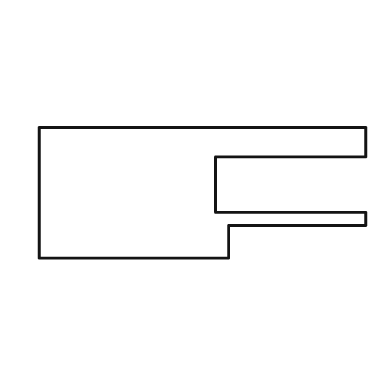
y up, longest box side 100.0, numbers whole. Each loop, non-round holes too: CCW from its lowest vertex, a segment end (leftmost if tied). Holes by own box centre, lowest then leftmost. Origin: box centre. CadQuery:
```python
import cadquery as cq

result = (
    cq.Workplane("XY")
    .moveTo(-50.0, -20.0)
    .lineTo(8.0, -20.0)
    .lineTo(8.0, -10.0)
    .lineTo(50.0, -10.0)
    .lineTo(50.0, -6.0)
    .lineTo(4.0, -6.0)
    .lineTo(4.0, 11.0)
    .lineTo(50.0, 11.0)
    .lineTo(50.0, 20.0)
    .lineTo(-50.0, 20.0)
    .close()
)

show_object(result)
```